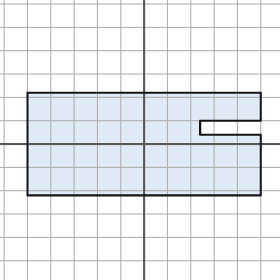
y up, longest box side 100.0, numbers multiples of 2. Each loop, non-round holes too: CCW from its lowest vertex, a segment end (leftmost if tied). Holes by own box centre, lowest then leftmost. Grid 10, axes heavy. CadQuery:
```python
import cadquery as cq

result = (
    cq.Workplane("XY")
    .moveTo(-50.0, -22.0)
    .lineTo(50.0, -22.0)
    .lineTo(50.0, 4.0)
    .lineTo(24.0, 4.0)
    .lineTo(24.0, 10.0)
    .lineTo(50.0, 10.0)
    .lineTo(50.0, 22.0)
    .lineTo(-50.0, 22.0)
    .close()
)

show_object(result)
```